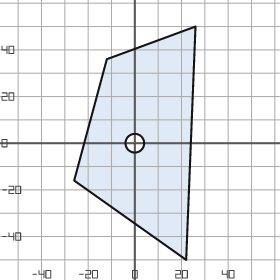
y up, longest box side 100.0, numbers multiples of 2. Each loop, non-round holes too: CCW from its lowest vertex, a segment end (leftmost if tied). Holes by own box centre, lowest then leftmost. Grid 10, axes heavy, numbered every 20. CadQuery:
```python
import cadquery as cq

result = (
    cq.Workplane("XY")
    .moveTo(22.0, -50.0)
    .lineTo(26.0, 50.0)
    .lineTo(-12.0, 36.0)
    .lineTo(-26.0, -16.0)
    .close()
    .moveTo(0.0, 0.0)
    .circle(4.0)
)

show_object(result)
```